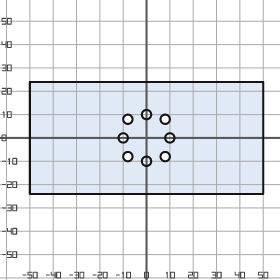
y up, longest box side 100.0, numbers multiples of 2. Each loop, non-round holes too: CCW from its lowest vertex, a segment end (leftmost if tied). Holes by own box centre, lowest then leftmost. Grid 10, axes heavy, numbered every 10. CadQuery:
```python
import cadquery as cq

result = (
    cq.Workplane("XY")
    .moveTo(-50.0, -24.0)
    .lineTo(50.0, -24.0)
    .lineTo(50.0, 24.0)
    .lineTo(-50.0, 24.0)
    .close()
    .moveTo(0.0, -10.0)
    .circle(2.0)
    .moveTo(-8.0, -8.0)
    .circle(2.0)
    .moveTo(8.0, -8.0)
    .circle(2.0)
    .moveTo(-10.0, 0.0)
    .circle(2.0)
    .moveTo(10.0, 0.0)
    .circle(2.0)
    .moveTo(-8.0, 8.0)
    .circle(2.0)
    .moveTo(8.0, 8.0)
    .circle(2.0)
    .moveTo(0.0, 10.0)
    .circle(2.0)
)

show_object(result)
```